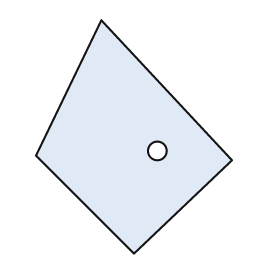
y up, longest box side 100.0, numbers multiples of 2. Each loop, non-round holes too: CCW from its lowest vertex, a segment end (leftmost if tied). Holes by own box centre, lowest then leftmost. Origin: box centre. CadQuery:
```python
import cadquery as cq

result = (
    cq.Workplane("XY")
    .moveTo(0.0, -50.0)
    .lineTo(42.0, -10.0)
    .lineTo(-14.0, 50.0)
    .lineTo(-42.0, -8.0)
    .close()
    .moveTo(10.0, -6.0)
    .circle(4.0)
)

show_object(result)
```